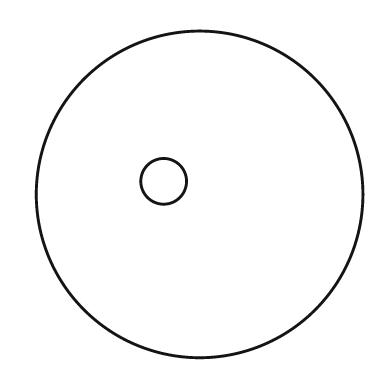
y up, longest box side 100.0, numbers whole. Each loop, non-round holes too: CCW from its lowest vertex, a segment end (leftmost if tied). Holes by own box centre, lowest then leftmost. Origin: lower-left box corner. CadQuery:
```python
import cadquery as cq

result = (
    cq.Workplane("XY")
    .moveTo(50.0, 50.0)
    .circle(50.0)
    .moveTo(39.0, 54.0)
    .circle(7.0)
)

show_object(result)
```